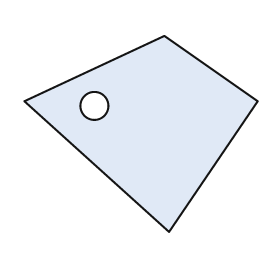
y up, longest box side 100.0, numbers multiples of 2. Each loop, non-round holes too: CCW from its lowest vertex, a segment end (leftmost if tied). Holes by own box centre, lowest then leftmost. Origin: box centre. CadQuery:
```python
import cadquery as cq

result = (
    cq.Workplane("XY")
    .moveTo(12.0, -42.0)
    .lineTo(50.0, 14.0)
    .lineTo(10.0, 42.0)
    .lineTo(-50.0, 14.0)
    .close()
    .moveTo(-20.0, 12.0)
    .circle(6.0)
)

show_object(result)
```